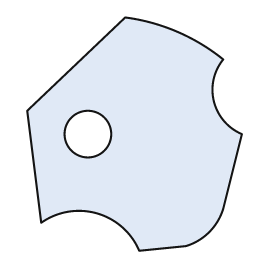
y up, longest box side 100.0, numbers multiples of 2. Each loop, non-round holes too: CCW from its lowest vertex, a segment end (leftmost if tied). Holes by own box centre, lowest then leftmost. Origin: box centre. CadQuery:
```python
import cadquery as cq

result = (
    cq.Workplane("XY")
    .moveTo(2.0, -50.0)
    .lineTo(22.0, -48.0)
    .threePointArc((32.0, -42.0), (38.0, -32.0))
    .lineTo(46.0, 0.0)
    .threePointArc((34.0, 14.0), (38.0, 32.0))
    .threePointArc((18.0, 44.0), (-4.0, 50.0))
    .lineTo(-46.0, 10.0)
    .lineTo(-40.0, -38.0)
    .threePointArc((-16.0, -34.0), (2.0, -50.0))
    .close()
    .moveTo(-20.0, 0.0)
    .circle(10.0)
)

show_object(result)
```